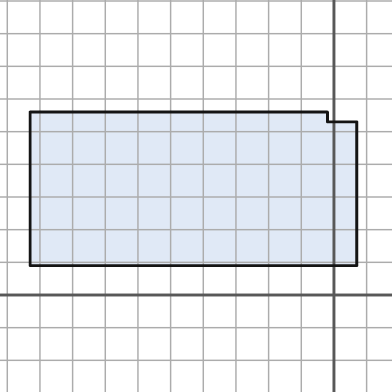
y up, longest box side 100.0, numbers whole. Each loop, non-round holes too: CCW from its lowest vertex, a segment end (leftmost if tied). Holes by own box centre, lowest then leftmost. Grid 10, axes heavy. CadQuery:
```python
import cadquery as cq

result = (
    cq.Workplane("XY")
    .moveTo(-93.0, 9.0)
    .lineTo(7.0, 9.0)
    .lineTo(7.0, 53.0)
    .lineTo(-2.0, 53.0)
    .lineTo(-2.0, 56.0)
    .lineTo(-93.0, 56.0)
    .close()
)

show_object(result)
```